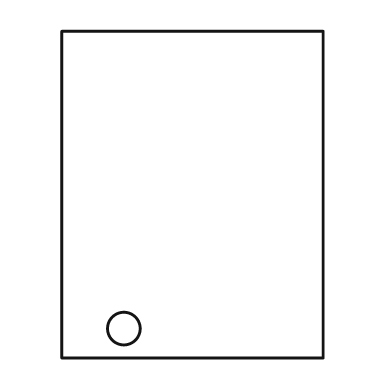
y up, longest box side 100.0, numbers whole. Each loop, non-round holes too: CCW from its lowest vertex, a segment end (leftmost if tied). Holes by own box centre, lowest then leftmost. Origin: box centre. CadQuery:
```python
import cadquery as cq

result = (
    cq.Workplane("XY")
    .moveTo(-40.0, -50.0)
    .lineTo(40.0, -50.0)
    .lineTo(40.0, 50.0)
    .lineTo(-40.0, 50.0)
    .close()
    .moveTo(-21.0, -41.0)
    .circle(5.0)
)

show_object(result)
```